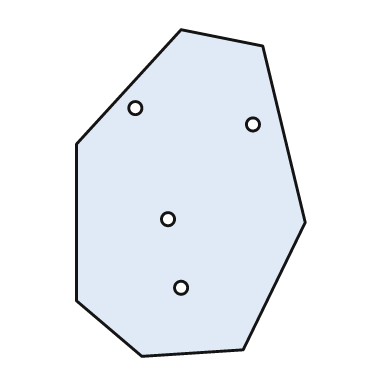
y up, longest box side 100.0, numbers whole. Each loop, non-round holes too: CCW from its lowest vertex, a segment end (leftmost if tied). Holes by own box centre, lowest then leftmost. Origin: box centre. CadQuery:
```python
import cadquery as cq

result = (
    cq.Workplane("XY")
    .moveTo(-15.0, -50.0)
    .lineTo(16.0, -48.0)
    .lineTo(35.0, -9.0)
    .lineTo(22.0, 45.0)
    .lineTo(-3.0, 50.0)
    .lineTo(-35.0, 15.0)
    .lineTo(-35.0, -33.0)
    .close()
    .moveTo(-3.0, -29.0)
    .circle(2.0)
    .moveTo(-7.0, -8.0)
    .circle(2.0)
    .moveTo(19.0, 21.0)
    .circle(2.0)
    .moveTo(-17.0, 26.0)
    .circle(2.0)
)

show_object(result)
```